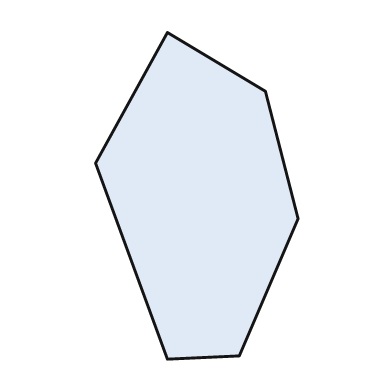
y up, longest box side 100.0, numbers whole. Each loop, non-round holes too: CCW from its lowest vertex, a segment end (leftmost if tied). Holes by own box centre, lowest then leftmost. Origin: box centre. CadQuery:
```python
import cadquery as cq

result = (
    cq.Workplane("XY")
    .moveTo(-9.0, -50.0)
    .lineTo(13.0, -49.0)
    .lineTo(31.0, -7.0)
    .lineTo(21.0, 32.0)
    .lineTo(-9.0, 50.0)
    .lineTo(-31.0, 10.0)
    .close()
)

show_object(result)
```